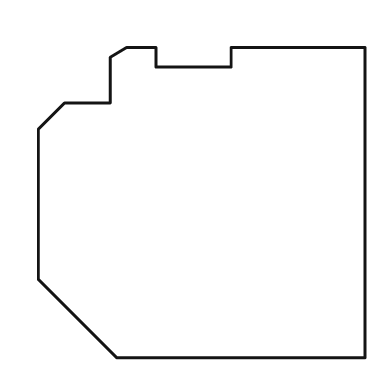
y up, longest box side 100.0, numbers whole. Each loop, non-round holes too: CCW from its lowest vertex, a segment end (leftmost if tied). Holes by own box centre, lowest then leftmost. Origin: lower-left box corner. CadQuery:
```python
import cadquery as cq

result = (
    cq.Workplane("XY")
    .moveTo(24.0, 0.0)
    .lineTo(100.0, 0.0)
    .lineTo(100.0, 95.0)
    .lineTo(59.0, 95.0)
    .lineTo(59.0, 89.0)
    .lineTo(36.0, 89.0)
    .lineTo(36.0, 95.0)
    .lineTo(27.0, 95.0)
    .lineTo(22.0, 92.0)
    .lineTo(22.0, 78.0)
    .lineTo(8.0, 78.0)
    .lineTo(0.0, 70.0)
    .lineTo(0.0, 24.0)
    .close()
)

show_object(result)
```